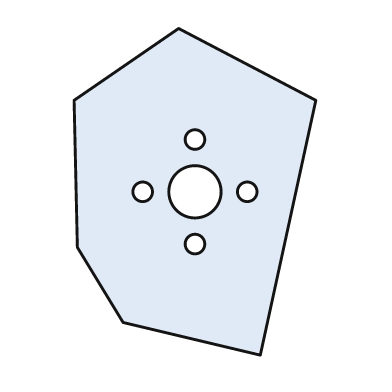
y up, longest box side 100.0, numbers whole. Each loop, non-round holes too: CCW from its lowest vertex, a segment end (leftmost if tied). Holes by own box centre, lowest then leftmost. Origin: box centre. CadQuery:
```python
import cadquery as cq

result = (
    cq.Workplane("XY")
    .moveTo(20.0, -50.0)
    .lineTo(37.0, 28.0)
    .lineTo(-5.0, 50.0)
    .lineTo(-37.0, 28.0)
    .lineTo(-36.0, -17.0)
    .lineTo(-22.0, -40.0)
    .close()
    .moveTo(0.0, -16.0)
    .circle(3.0)
    .moveTo(-16.0, 0.0)
    .circle(3.0)
    .moveTo(0.0, 0.0)
    .circle(8.0)
    .moveTo(16.0, 0.0)
    .circle(3.0)
    .moveTo(0.0, 16.0)
    .circle(3.0)
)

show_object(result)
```